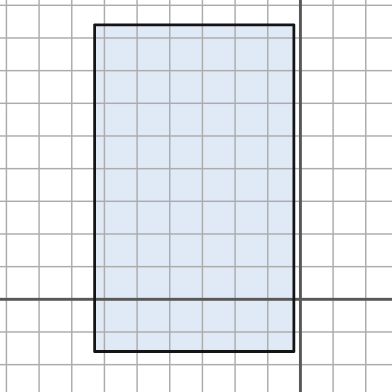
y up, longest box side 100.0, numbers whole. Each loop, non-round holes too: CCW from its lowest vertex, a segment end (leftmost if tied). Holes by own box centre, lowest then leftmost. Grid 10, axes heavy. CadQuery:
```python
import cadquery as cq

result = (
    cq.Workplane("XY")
    .moveTo(-63.0, -16.0)
    .lineTo(-2.0, -16.0)
    .lineTo(-2.0, 84.0)
    .lineTo(-63.0, 84.0)
    .close()
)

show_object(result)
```